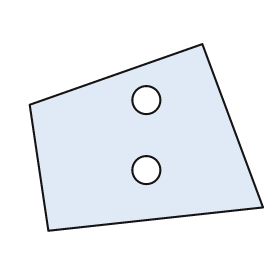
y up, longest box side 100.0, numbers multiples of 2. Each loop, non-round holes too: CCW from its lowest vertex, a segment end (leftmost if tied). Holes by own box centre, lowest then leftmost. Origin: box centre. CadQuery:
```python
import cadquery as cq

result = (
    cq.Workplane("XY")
    .moveTo(-42.0, -40.0)
    .lineTo(50.0, -30.0)
    .lineTo(24.0, 40.0)
    .lineTo(-50.0, 14.0)
    .close()
    .moveTo(0.0, -14.0)
    .circle(6.0)
    .moveTo(0.0, 16.0)
    .circle(6.0)
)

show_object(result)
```